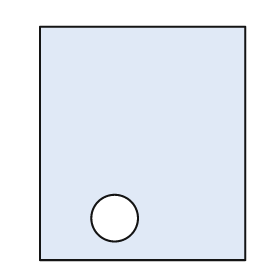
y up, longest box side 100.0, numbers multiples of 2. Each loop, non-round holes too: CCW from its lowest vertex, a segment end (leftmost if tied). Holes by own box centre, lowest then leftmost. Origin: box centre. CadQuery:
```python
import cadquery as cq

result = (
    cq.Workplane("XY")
    .moveTo(-44.0, -50.0)
    .lineTo(44.0, -50.0)
    .lineTo(44.0, 50.0)
    .lineTo(-44.0, 50.0)
    .close()
    .moveTo(-12.0, -32.0)
    .circle(10.0)
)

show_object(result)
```